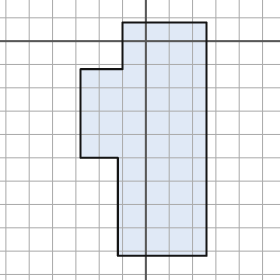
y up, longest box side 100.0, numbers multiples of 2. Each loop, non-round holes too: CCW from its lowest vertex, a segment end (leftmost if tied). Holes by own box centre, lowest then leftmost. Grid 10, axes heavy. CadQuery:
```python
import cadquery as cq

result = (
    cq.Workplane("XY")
    .moveTo(-12.0, -92.0)
    .lineTo(26.0, -92.0)
    .lineTo(26.0, 8.0)
    .lineTo(-10.0, 8.0)
    .lineTo(-10.0, -12.0)
    .lineTo(-28.0, -12.0)
    .lineTo(-28.0, -50.0)
    .lineTo(-12.0, -50.0)
    .close()
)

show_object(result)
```